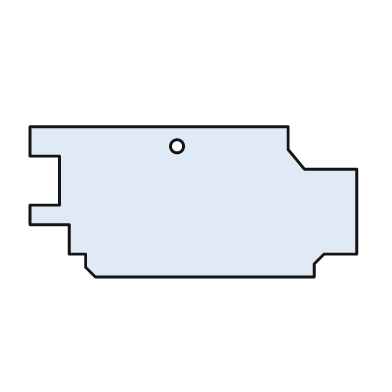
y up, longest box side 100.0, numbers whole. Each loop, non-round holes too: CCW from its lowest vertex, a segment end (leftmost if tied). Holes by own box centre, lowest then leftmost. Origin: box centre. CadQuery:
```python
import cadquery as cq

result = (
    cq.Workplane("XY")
    .moveTo(-30.0, -23.0)
    .lineTo(37.0, -23.0)
    .lineTo(37.0, -19.0)
    .lineTo(40.0, -16.0)
    .lineTo(50.0, -16.0)
    .lineTo(50.0, 10.0)
    .lineTo(34.0, 10.0)
    .lineTo(29.0, 16.0)
    .lineTo(29.0, 23.0)
    .lineTo(-50.0, 23.0)
    .lineTo(-50.0, 14.0)
    .lineTo(-41.0, 14.0)
    .lineTo(-41.0, -1.0)
    .lineTo(-50.0, -1.0)
    .lineTo(-50.0, -7.0)
    .lineTo(-38.0, -7.0)
    .lineTo(-38.0, -16.0)
    .lineTo(-33.0, -16.0)
    .lineTo(-33.0, -20.0)
    .close()
    .moveTo(-5.0, 17.0)
    .circle(2.0)
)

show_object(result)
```